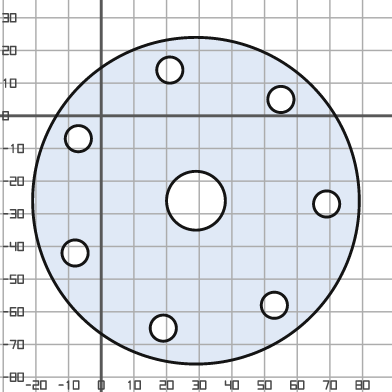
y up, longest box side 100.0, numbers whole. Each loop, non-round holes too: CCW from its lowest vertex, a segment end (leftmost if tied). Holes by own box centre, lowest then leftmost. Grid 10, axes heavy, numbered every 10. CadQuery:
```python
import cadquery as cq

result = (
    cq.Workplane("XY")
    .moveTo(29.0, -26.0)
    .circle(50.0)
    .moveTo(19.0, -65.0)
    .circle(4.0)
    .moveTo(53.0, -58.0)
    .circle(4.0)
    .moveTo(-8.0, -42.0)
    .circle(4.0)
    .moveTo(69.0, -27.0)
    .circle(4.0)
    .moveTo(29.0, -26.0)
    .circle(9.0)
    .moveTo(-7.0, -7.0)
    .circle(4.0)
    .moveTo(55.0, 5.0)
    .circle(4.0)
    .moveTo(21.0, 14.0)
    .circle(4.0)
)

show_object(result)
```